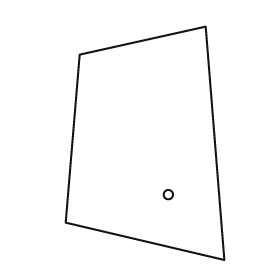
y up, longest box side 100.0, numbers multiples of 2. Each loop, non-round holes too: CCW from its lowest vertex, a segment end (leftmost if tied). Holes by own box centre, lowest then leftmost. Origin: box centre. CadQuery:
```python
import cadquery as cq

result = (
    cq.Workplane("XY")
    .moveTo(34.0, -50.0)
    .lineTo(26.0, 50.0)
    .lineTo(-28.0, 38.0)
    .lineTo(-34.0, -34.0)
    .close()
    .moveTo(10.0, -22.0)
    .circle(2.0)
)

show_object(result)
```